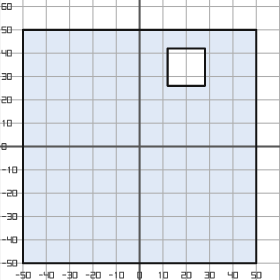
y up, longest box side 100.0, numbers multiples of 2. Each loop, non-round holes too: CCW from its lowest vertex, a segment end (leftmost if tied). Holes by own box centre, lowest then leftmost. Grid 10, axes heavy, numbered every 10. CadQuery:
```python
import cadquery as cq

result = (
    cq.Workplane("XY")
    .moveTo(-50.0, -50.0)
    .lineTo(50.0, -50.0)
    .lineTo(50.0, 50.0)
    .lineTo(-50.0, 50.0)
    .close()
    .moveTo(12.0, 26.0)
    .lineTo(28.0, 26.0)
    .lineTo(28.0, 42.0)
    .lineTo(12.0, 42.0)
    .close()
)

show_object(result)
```